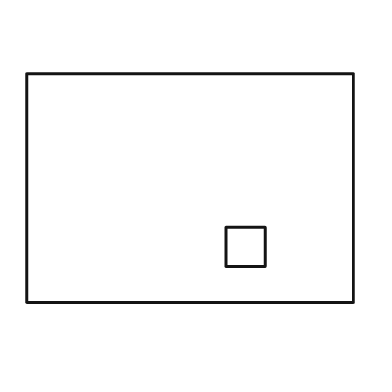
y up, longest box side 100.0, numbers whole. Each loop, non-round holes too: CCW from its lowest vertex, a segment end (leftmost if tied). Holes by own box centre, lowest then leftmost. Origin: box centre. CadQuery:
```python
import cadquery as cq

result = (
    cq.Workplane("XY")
    .moveTo(-50.0, -35.0)
    .lineTo(50.0, -35.0)
    .lineTo(50.0, 35.0)
    .lineTo(-50.0, 35.0)
    .close()
    .moveTo(11.0, -24.0)
    .lineTo(23.0, -24.0)
    .lineTo(23.0, -12.0)
    .lineTo(11.0, -12.0)
    .close()
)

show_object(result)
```